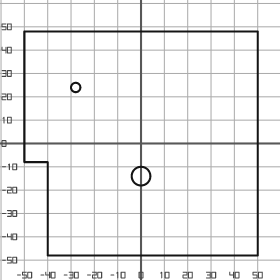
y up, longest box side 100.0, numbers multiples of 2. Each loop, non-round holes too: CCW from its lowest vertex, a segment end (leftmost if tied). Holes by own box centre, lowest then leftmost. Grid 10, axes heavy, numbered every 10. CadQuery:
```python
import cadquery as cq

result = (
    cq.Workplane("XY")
    .moveTo(-40.0, -48.0)
    .lineTo(50.0, -48.0)
    .lineTo(50.0, 48.0)
    .lineTo(-50.0, 48.0)
    .lineTo(-50.0, -8.0)
    .lineTo(-40.0, -8.0)
    .close()
    .moveTo(0.0, -14.0)
    .circle(4.0)
    .moveTo(-28.0, 24.0)
    .circle(2.0)
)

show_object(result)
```